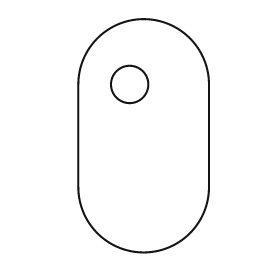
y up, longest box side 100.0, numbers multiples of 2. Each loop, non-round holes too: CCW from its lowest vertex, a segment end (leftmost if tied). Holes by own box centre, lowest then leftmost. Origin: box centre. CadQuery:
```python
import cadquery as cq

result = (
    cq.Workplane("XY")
    .moveTo(-28.0, -22.0)
    .threePointArc((0.0, -50.0), (28.0, -22.0))
    .lineTo(28.0, 22.0)
    .threePointArc((0.0, 50.0), (-28.0, 22.0))
    .close()
    .moveTo(-6.0, 22.0)
    .circle(8.0)
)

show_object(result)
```